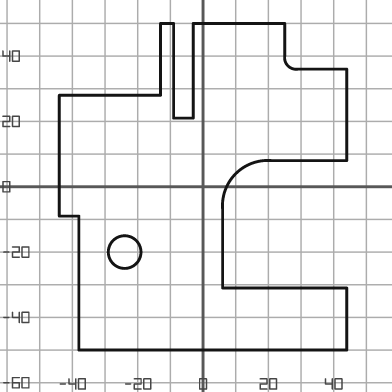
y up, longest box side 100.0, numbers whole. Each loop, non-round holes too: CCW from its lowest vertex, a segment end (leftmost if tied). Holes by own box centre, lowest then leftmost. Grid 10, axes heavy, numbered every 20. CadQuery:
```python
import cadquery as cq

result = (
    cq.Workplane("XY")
    .moveTo(-38.0, -50.0)
    .lineTo(44.0, -50.0)
    .lineTo(44.0, -31.0)
    .lineTo(6.0, -31.0)
    .lineTo(6.0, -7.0)
    .threePointArc((10.0, 4.0), (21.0, 8.0))
    .lineTo(44.0, 8.0)
    .lineTo(44.0, 36.0)
    .lineTo(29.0, 36.0)
    .threePointArc((26.0, 37.0), (25.0, 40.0))
    .lineTo(25.0, 50.0)
    .lineTo(-3.0, 50.0)
    .lineTo(-3.0, 21.0)
    .lineTo(-9.0, 21.0)
    .lineTo(-9.0, 50.0)
    .lineTo(-13.0, 50.0)
    .lineTo(-13.0, 28.0)
    .lineTo(-44.0, 28.0)
    .lineTo(-44.0, -9.0)
    .lineTo(-38.0, -9.0)
    .close()
    .moveTo(-24.0, -20.0)
    .circle(5.0)
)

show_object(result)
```